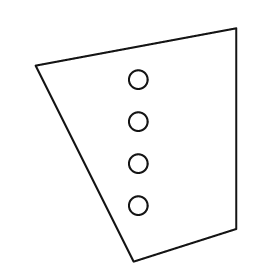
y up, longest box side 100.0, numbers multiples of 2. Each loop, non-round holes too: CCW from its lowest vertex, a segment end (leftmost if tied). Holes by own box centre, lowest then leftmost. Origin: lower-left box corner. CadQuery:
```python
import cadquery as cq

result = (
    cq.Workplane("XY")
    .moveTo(42.0, 0.0)
    .lineTo(86.0, 14.0)
    .lineTo(86.0, 100.0)
    .lineTo(0.0, 84.0)
    .close()
    .moveTo(44.0, 24.0)
    .circle(4.0)
    .moveTo(44.0, 42.0)
    .circle(4.0)
    .moveTo(44.0, 60.0)
    .circle(4.0)
    .moveTo(44.0, 78.0)
    .circle(4.0)
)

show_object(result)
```